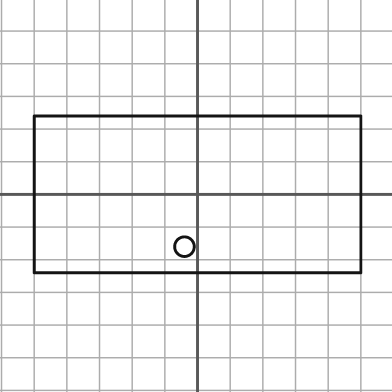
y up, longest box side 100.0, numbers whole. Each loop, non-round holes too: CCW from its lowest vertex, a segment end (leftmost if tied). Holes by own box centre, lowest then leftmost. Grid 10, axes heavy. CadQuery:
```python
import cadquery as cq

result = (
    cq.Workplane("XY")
    .moveTo(-50.0, -24.0)
    .lineTo(50.0, -24.0)
    .lineTo(50.0, 24.0)
    .lineTo(-50.0, 24.0)
    .close()
    .moveTo(-4.0, -16.0)
    .circle(3.0)
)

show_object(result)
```